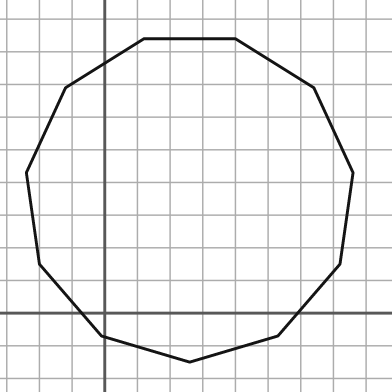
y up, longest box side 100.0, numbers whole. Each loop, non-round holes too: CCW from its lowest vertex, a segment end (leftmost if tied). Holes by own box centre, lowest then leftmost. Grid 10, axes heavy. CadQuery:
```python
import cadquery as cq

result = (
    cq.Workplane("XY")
    .moveTo(26.0, -15.0)
    .lineTo(53.0, -7.0)
    .lineTo(72.0, 15.0)
    .lineTo(76.0, 43.0)
    .lineTo(64.0, 69.0)
    .lineTo(40.0, 84.0)
    .lineTo(12.0, 84.0)
    .lineTo(-12.0, 69.0)
    .lineTo(-24.0, 43.0)
    .lineTo(-20.0, 15.0)
    .lineTo(-1.0, -7.0)
    .close()
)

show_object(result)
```